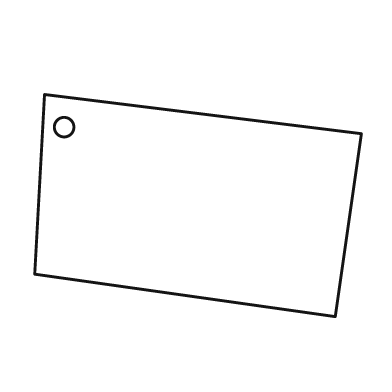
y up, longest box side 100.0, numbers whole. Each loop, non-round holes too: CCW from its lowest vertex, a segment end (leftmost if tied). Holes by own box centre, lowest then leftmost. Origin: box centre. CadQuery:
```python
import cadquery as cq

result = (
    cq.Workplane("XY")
    .moveTo(42.0, -34.0)
    .lineTo(50.0, 22.0)
    .lineTo(-47.0, 34.0)
    .lineTo(-50.0, -21.0)
    .close()
    .moveTo(-41.0, 24.0)
    .circle(3.0)
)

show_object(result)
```